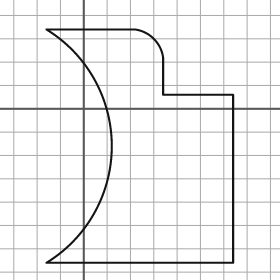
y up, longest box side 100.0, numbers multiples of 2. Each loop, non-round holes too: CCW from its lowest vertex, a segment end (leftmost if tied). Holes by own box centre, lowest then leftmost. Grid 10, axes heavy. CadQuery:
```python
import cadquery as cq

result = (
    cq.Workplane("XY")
    .moveTo(-16.0, -66.0)
    .lineTo(64.0, -66.0)
    .lineTo(64.0, 6.0)
    .lineTo(34.0, 6.0)
    .lineTo(34.0, 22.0)
    .threePointArc((30.0, 30.0), (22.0, 34.0))
    .lineTo(-16.0, 34.0)
    .threePointArc((12.0, -16.0), (-16.0, -66.0))
    .close()
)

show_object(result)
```